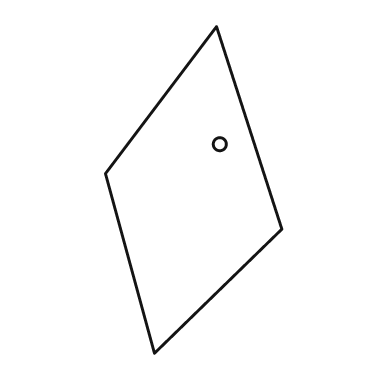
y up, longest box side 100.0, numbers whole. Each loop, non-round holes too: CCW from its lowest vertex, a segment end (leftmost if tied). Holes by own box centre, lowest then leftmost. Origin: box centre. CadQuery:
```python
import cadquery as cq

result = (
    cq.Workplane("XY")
    .moveTo(-12.0, -50.0)
    .lineTo(27.0, -12.0)
    .lineTo(7.0, 50.0)
    .lineTo(-27.0, 5.0)
    .close()
    .moveTo(8.0, 14.0)
    .circle(2.0)
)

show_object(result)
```